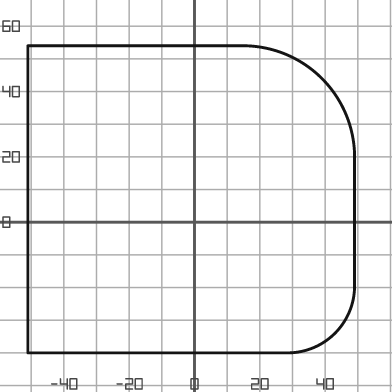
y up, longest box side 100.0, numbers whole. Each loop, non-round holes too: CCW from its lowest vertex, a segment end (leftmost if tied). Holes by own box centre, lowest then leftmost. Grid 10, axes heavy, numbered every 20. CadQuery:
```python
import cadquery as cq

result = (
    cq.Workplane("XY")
    .moveTo(-51.0, -40.0)
    .lineTo(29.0, -40.0)
    .threePointArc((43.0, -34.0), (49.0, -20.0))
    .lineTo(49.0, 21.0)
    .threePointArc((39.0, 44.0), (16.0, 54.0))
    .lineTo(-51.0, 54.0)
    .close()
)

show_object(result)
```